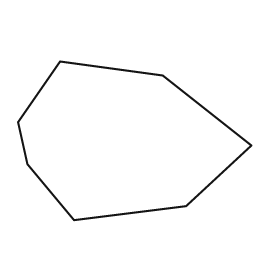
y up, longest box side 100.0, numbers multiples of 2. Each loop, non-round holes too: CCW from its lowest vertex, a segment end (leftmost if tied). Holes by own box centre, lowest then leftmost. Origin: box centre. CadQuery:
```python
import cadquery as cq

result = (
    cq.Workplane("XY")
    .moveTo(-26.0, -34.0)
    .lineTo(22.0, -28.0)
    .lineTo(50.0, -2.0)
    .lineTo(12.0, 28.0)
    .lineTo(-32.0, 34.0)
    .lineTo(-50.0, 8.0)
    .lineTo(-46.0, -10.0)
    .close()
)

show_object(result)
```